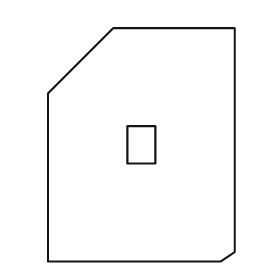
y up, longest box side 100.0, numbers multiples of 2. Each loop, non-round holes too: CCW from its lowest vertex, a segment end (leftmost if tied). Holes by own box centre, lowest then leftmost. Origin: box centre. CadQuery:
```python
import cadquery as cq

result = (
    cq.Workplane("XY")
    .moveTo(-40.0, -50.0)
    .lineTo(34.0, -50.0)
    .lineTo(40.0, -46.0)
    .lineTo(40.0, 50.0)
    .lineTo(-12.0, 50.0)
    .lineTo(-40.0, 22.0)
    .close()
    .moveTo(-6.0, -8.0)
    .lineTo(6.0, -8.0)
    .lineTo(6.0, 8.0)
    .lineTo(-6.0, 8.0)
    .close()
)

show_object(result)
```